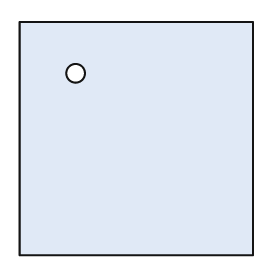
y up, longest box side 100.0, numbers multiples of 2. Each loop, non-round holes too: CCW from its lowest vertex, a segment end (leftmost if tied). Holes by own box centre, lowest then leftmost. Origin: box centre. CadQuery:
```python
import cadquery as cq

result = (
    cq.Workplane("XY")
    .moveTo(-50.0, -50.0)
    .lineTo(50.0, -50.0)
    .lineTo(50.0, 50.0)
    .lineTo(-50.0, 50.0)
    .close()
    .moveTo(-26.0, 28.0)
    .circle(4.0)
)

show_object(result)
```